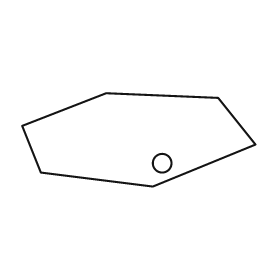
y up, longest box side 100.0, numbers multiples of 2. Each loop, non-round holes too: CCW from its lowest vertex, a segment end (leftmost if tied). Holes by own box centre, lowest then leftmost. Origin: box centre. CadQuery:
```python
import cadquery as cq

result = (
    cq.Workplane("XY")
    .moveTo(6.0, -20.0)
    .lineTo(50.0, -2.0)
    .lineTo(34.0, 18.0)
    .lineTo(-14.0, 20.0)
    .lineTo(-50.0, 6.0)
    .lineTo(-42.0, -14.0)
    .close()
    .moveTo(10.0, -10.0)
    .circle(4.0)
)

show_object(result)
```